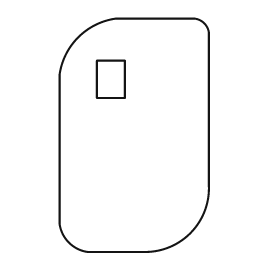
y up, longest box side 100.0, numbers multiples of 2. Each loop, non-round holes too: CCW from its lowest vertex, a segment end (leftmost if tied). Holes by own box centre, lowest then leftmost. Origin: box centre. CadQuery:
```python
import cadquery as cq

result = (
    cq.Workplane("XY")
    .moveTo(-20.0, -50.0)
    .lineTo(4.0, -50.0)
    .threePointArc((24.0, -42.0), (32.0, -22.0))
    .lineTo(32.0, 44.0)
    .threePointArc((30.0, 48.0), (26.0, 50.0))
    .lineTo(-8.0, 50.0)
    .threePointArc((-24.0, 42.0), (-32.0, 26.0))
    .lineTo(-32.0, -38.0)
    .threePointArc((-28.0, -46.0), (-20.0, -50.0))
    .close()
    .moveTo(-16.0, 16.0)
    .lineTo(-4.0, 16.0)
    .lineTo(-4.0, 32.0)
    .lineTo(-16.0, 32.0)
    .close()
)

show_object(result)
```